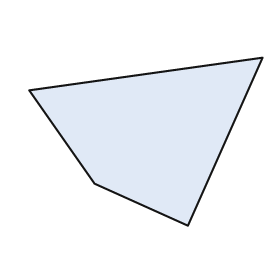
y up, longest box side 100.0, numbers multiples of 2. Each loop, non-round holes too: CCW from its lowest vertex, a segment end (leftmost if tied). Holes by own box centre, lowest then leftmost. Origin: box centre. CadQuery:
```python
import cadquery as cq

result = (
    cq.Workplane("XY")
    .moveTo(18.0, -36.0)
    .lineTo(50.0, 36.0)
    .lineTo(-50.0, 22.0)
    .lineTo(-22.0, -18.0)
    .close()
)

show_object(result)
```